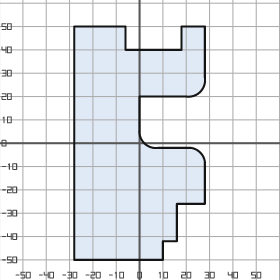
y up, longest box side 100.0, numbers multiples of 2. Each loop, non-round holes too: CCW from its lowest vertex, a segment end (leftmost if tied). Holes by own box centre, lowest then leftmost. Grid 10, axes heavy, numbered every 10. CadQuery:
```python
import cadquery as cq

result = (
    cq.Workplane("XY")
    .moveTo(-28.0, -50.0)
    .lineTo(10.0, -50.0)
    .lineTo(10.0, -42.0)
    .lineTo(16.0, -42.0)
    .lineTo(16.0, -26.0)
    .lineTo(28.0, -26.0)
    .lineTo(28.0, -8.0)
    .threePointArc((26.0, -4.0), (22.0, -2.0))
    .lineTo(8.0, -2.0)
    .threePointArc((2.0, 0.0), (0.0, 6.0))
    .lineTo(0.0, 20.0)
    .lineTo(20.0, 20.0)
    .threePointArc((26.0, 22.0), (28.0, 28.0))
    .lineTo(28.0, 50.0)
    .lineTo(18.0, 50.0)
    .lineTo(18.0, 40.0)
    .lineTo(-6.0, 40.0)
    .lineTo(-6.0, 50.0)
    .lineTo(-28.0, 50.0)
    .close()
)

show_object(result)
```